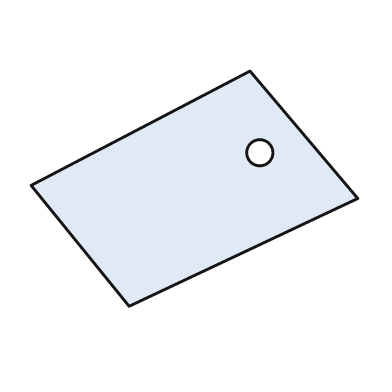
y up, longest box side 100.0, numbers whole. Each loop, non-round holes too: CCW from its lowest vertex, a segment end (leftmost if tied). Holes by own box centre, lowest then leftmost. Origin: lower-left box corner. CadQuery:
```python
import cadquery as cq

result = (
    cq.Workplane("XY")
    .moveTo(30.0, 0.0)
    .lineTo(100.0, 33.0)
    .lineTo(67.0, 72.0)
    .lineTo(0.0, 37.0)
    .close()
    .moveTo(70.0, 47.0)
    .circle(4.0)
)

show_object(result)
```